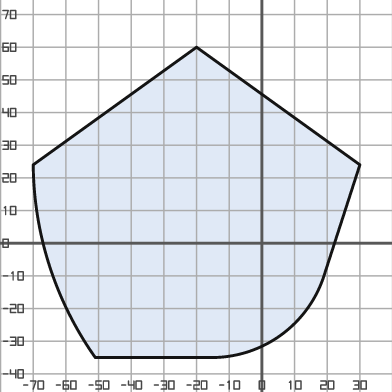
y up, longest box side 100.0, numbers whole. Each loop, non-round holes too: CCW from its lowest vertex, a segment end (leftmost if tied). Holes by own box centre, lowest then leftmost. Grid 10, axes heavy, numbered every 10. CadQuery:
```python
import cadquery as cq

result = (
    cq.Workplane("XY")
    .moveTo(-51.0, -35.0)
    .lineTo(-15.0, -35.0)
    .threePointArc((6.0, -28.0), (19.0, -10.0))
    .lineTo(30.0, 24.0)
    .lineTo(-20.0, 60.0)
    .lineTo(-70.0, 24.0)
    .threePointArc((-65.0, -7.0), (-51.0, -35.0))
    .close()
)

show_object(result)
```